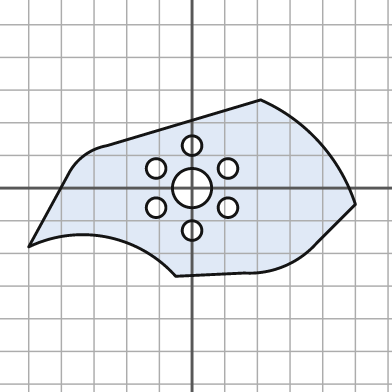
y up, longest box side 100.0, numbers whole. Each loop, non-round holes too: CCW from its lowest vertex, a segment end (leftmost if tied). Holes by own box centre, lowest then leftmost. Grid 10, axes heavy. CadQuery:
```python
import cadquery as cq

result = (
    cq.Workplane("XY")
    .moveTo(-5.0, -27.0)
    .lineTo(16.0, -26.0)
    .threePointArc((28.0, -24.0), (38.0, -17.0))
    .lineTo(50.0, -5.0)
    .threePointArc((39.0, 14.0), (21.0, 27.0))
    .lineTo(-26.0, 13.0)
    .threePointArc((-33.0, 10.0), (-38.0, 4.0))
    .lineTo(-50.0, -18.0)
    .threePointArc((-26.0, -15.0), (-5.0, -27.0))
    .close()
    .moveTo(0.0, -13.0)
    .circle(3.0)
    .moveTo(-11.0, -6.0)
    .circle(3.0)
    .moveTo(11.0, -6.0)
    .circle(3.0)
    .moveTo(0.0, 0.0)
    .circle(6.0)
    .moveTo(-11.0, 6.0)
    .circle(3.0)
    .moveTo(11.0, 6.0)
    .circle(3.0)
    .moveTo(0.0, 13.0)
    .circle(3.0)
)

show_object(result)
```